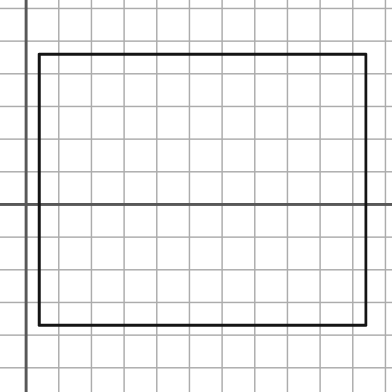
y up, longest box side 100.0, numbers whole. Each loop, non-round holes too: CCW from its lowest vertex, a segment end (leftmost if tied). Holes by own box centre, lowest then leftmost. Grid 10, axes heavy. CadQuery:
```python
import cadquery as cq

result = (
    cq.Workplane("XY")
    .moveTo(4.0, -37.0)
    .lineTo(104.0, -37.0)
    .lineTo(104.0, 46.0)
    .lineTo(4.0, 46.0)
    .close()
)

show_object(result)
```